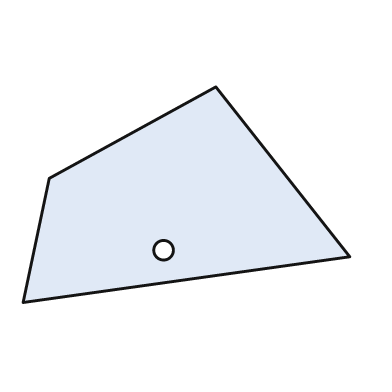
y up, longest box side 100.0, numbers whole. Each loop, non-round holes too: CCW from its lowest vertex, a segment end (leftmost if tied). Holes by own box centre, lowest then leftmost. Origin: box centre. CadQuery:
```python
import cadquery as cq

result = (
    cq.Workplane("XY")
    .moveTo(-50.0, -33.0)
    .lineTo(50.0, -19.0)
    .lineTo(9.0, 33.0)
    .lineTo(-42.0, 5.0)
    .close()
    .moveTo(-7.0, -17.0)
    .circle(3.0)
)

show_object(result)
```